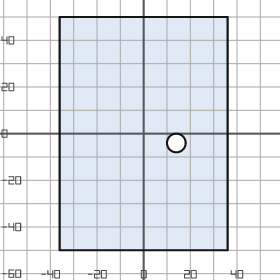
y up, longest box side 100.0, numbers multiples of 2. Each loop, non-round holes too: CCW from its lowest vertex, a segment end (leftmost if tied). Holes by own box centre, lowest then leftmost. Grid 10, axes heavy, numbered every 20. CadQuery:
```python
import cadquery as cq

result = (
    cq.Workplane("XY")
    .moveTo(-36.0, -50.0)
    .lineTo(36.0, -50.0)
    .lineTo(36.0, 50.0)
    .lineTo(-36.0, 50.0)
    .close()
    .moveTo(14.0, -4.0)
    .circle(4.0)
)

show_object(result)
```